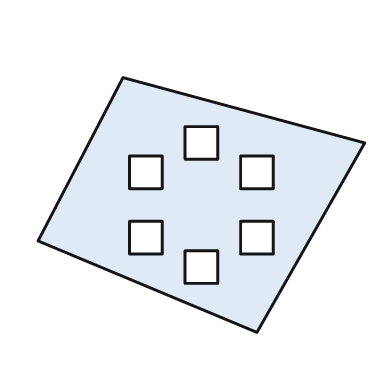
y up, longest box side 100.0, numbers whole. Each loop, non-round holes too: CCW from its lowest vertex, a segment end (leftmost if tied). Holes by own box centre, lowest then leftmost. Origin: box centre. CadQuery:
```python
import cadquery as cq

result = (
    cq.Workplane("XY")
    .moveTo(17.0, -39.0)
    .lineTo(50.0, 19.0)
    .lineTo(-24.0, 39.0)
    .lineTo(-50.0, -11.0)
    .close()
    .moveTo(-5.0, -24.0)
    .lineTo(5.0, -24.0)
    .lineTo(5.0, -14.0)
    .lineTo(-5.0, -14.0)
    .close()
    .moveTo(-22.0, -15.0)
    .lineTo(-12.0, -15.0)
    .lineTo(-12.0, -5.0)
    .lineTo(-22.0, -5.0)
    .close()
    .moveTo(12.0, -15.0)
    .lineTo(22.0, -15.0)
    .lineTo(22.0, -5.0)
    .lineTo(12.0, -5.0)
    .close()
    .moveTo(-22.0, 5.0)
    .lineTo(-12.0, 5.0)
    .lineTo(-12.0, 15.0)
    .lineTo(-22.0, 15.0)
    .close()
    .moveTo(12.0, 5.0)
    .lineTo(22.0, 5.0)
    .lineTo(22.0, 15.0)
    .lineTo(12.0, 15.0)
    .close()
    .moveTo(-5.0, 14.0)
    .lineTo(5.0, 14.0)
    .lineTo(5.0, 24.0)
    .lineTo(-5.0, 24.0)
    .close()
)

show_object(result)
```